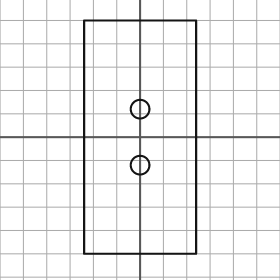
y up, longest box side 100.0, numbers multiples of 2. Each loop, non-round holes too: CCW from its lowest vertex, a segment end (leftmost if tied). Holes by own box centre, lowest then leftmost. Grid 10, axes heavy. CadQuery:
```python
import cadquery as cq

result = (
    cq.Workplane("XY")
    .moveTo(-24.0, -50.0)
    .lineTo(24.0, -50.0)
    .lineTo(24.0, 50.0)
    .lineTo(-24.0, 50.0)
    .close()
    .moveTo(0.0, -12.0)
    .circle(4.0)
    .moveTo(0.0, 12.0)
    .circle(4.0)
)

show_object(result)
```